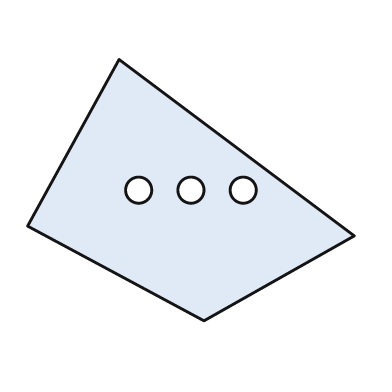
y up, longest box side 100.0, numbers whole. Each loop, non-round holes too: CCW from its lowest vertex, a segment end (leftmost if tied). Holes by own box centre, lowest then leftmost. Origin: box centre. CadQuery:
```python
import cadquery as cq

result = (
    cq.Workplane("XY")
    .moveTo(4.0, -40.0)
    .lineTo(50.0, -14.0)
    .lineTo(-22.0, 40.0)
    .lineTo(-50.0, -11.0)
    .close()
    .moveTo(-16.0, 0.0)
    .circle(4.0)
    .moveTo(0.0, 0.0)
    .circle(4.0)
    .moveTo(16.0, 0.0)
    .circle(4.0)
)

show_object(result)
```